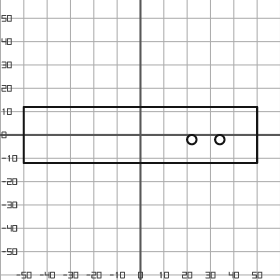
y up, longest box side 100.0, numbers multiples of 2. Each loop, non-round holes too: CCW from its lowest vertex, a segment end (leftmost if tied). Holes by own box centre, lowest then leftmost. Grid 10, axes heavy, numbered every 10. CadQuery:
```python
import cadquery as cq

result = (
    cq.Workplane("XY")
    .moveTo(-50.0, -12.0)
    .lineTo(50.0, -12.0)
    .lineTo(50.0, 12.0)
    .lineTo(-50.0, 12.0)
    .close()
    .moveTo(22.0, -2.0)
    .circle(2.0)
    .moveTo(34.0, -2.0)
    .circle(2.0)
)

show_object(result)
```